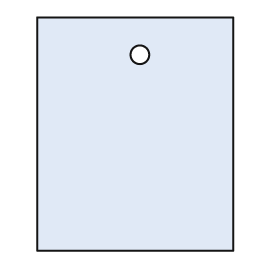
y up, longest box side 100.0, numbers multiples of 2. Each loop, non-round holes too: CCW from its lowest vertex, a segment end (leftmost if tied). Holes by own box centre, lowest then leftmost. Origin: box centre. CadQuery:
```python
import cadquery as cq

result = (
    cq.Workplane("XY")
    .moveTo(-42.0, -50.0)
    .lineTo(42.0, -50.0)
    .lineTo(42.0, 50.0)
    .lineTo(-42.0, 50.0)
    .close()
    .moveTo(2.0, 34.0)
    .circle(4.0)
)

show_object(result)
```